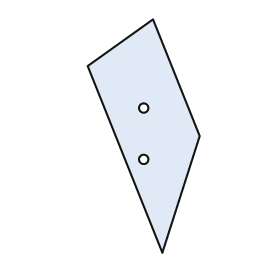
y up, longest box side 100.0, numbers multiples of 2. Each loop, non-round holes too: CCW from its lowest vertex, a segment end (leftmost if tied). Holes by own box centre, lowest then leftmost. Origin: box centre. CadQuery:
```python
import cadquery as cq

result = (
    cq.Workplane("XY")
    .moveTo(8.0, -50.0)
    .lineTo(24.0, 0.0)
    .lineTo(4.0, 50.0)
    .lineTo(-24.0, 30.0)
    .close()
    .moveTo(0.0, -10.0)
    .circle(2.0)
    .moveTo(0.0, 12.0)
    .circle(2.0)
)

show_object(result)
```